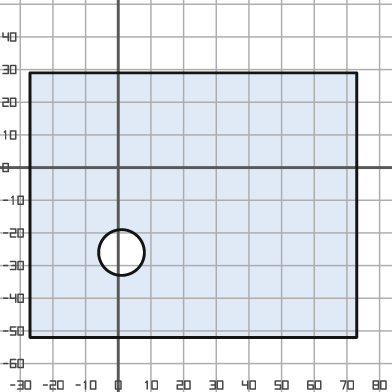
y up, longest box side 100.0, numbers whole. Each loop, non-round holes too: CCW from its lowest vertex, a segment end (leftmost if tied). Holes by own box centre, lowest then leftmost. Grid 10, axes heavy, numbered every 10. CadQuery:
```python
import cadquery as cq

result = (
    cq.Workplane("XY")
    .moveTo(-27.0, -52.0)
    .lineTo(73.0, -52.0)
    .lineTo(73.0, 29.0)
    .lineTo(-27.0, 29.0)
    .close()
    .moveTo(1.0, -26.0)
    .circle(7.0)
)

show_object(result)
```